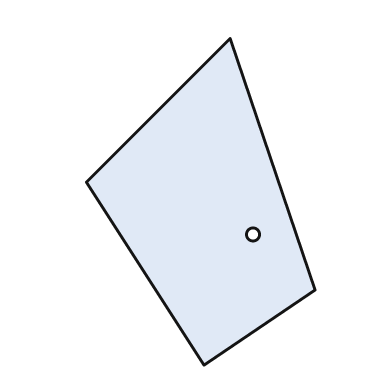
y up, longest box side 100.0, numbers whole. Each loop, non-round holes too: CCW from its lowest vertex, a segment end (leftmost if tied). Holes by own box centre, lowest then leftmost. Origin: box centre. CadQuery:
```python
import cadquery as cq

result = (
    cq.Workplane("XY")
    .moveTo(1.0, -50.0)
    .lineTo(35.0, -27.0)
    .lineTo(9.0, 50.0)
    .lineTo(-35.0, 6.0)
    .close()
    .moveTo(16.0, -10.0)
    .circle(2.0)
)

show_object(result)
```